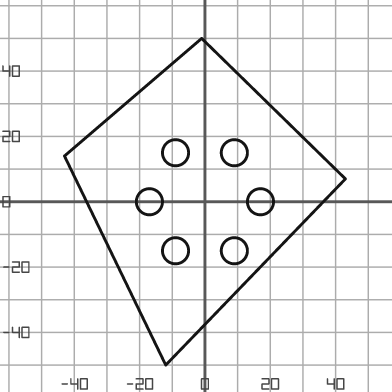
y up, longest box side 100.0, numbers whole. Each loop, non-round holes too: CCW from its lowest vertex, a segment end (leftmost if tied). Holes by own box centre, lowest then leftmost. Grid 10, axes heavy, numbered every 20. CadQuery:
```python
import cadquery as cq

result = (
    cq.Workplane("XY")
    .moveTo(-12.0, -50.0)
    .lineTo(43.0, 7.0)
    .lineTo(-1.0, 50.0)
    .lineTo(-43.0, 14.0)
    .close()
    .moveTo(-9.0, -15.0)
    .circle(4.0)
    .moveTo(9.0, -15.0)
    .circle(4.0)
    .moveTo(-17.0, 0.0)
    .circle(4.0)
    .moveTo(17.0, 0.0)
    .circle(4.0)
    .moveTo(-9.0, 15.0)
    .circle(4.0)
    .moveTo(9.0, 15.0)
    .circle(4.0)
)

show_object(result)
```